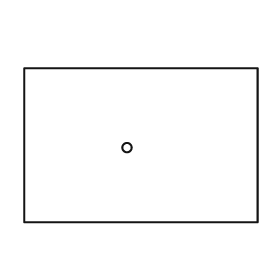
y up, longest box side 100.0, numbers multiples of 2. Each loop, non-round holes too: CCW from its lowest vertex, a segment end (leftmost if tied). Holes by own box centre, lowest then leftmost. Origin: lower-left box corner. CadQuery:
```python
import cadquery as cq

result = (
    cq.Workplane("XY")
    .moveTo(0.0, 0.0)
    .lineTo(100.0, 0.0)
    .lineTo(100.0, 66.0)
    .lineTo(0.0, 66.0)
    .close()
    .moveTo(44.0, 32.0)
    .circle(2.0)
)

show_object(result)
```